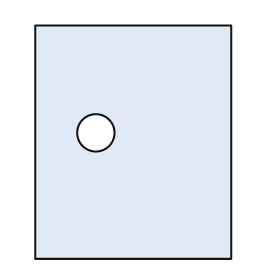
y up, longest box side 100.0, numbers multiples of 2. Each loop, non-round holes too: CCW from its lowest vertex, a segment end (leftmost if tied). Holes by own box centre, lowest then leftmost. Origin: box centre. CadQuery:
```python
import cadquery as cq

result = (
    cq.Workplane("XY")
    .moveTo(-42.0, -50.0)
    .lineTo(42.0, -50.0)
    .lineTo(42.0, 50.0)
    .lineTo(-42.0, 50.0)
    .close()
    .moveTo(-16.0, 4.0)
    .circle(8.0)
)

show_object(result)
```